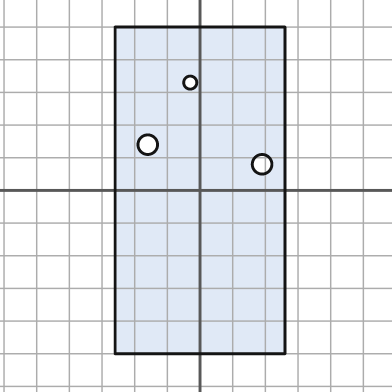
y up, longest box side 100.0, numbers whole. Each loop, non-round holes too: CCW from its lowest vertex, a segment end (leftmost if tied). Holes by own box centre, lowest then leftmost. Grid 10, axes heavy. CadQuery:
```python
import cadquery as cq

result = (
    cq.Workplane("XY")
    .moveTo(-26.0, -50.0)
    .lineTo(26.0, -50.0)
    .lineTo(26.0, 50.0)
    .lineTo(-26.0, 50.0)
    .close()
    .moveTo(19.0, 8.0)
    .circle(3.0)
    .moveTo(-16.0, 14.0)
    .circle(3.0)
    .moveTo(-3.0, 33.0)
    .circle(2.0)
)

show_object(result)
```